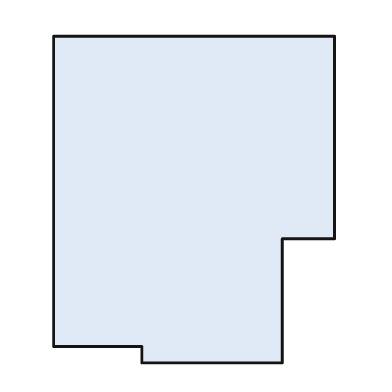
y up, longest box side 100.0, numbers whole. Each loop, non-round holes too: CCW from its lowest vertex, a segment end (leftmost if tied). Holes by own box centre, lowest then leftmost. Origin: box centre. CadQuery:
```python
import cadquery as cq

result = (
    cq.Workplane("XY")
    .moveTo(-16.0, -50.0)
    .lineTo(27.0, -50.0)
    .lineTo(27.0, -12.0)
    .lineTo(43.0, -12.0)
    .lineTo(43.0, 50.0)
    .lineTo(-43.0, 50.0)
    .lineTo(-43.0, -45.0)
    .lineTo(-16.0, -45.0)
    .close()
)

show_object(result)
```